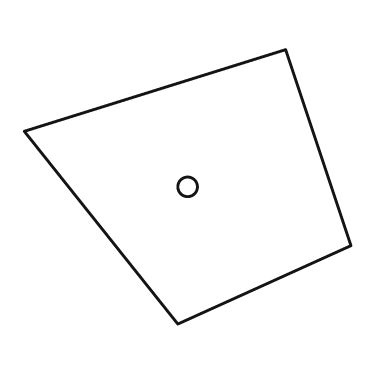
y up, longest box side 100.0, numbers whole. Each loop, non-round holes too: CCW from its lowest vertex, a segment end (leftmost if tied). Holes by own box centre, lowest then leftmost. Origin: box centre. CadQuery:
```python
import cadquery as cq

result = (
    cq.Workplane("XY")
    .moveTo(-3.0, -42.0)
    .lineTo(50.0, -18.0)
    .lineTo(30.0, 42.0)
    .lineTo(-50.0, 17.0)
    .close()
    .moveTo(0.0, 0.0)
    .circle(3.0)
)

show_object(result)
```